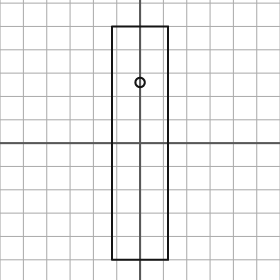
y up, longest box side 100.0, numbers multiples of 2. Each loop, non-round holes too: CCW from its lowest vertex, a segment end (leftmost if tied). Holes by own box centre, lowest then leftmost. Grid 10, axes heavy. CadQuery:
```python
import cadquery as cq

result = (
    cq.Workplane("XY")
    .moveTo(-12.0, -50.0)
    .lineTo(12.0, -50.0)
    .lineTo(12.0, 50.0)
    .lineTo(-12.0, 50.0)
    .close()
    .moveTo(0.0, 26.0)
    .circle(2.0)
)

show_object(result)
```